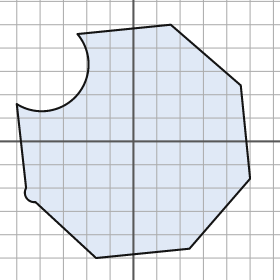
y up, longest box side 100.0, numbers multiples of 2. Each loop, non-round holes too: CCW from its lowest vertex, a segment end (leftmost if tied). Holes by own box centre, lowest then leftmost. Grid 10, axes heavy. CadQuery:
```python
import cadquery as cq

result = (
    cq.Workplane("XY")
    .moveTo(-16.0, -50.0)
    .lineTo(24.0, -46.0)
    .lineTo(50.0, -16.0)
    .lineTo(46.0, 24.0)
    .lineTo(16.0, 50.0)
    .lineTo(-24.0, 46.0)
    .threePointArc((-24.0, 20.0), (-50.0, 16.0))
    .lineTo(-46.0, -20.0)
    .threePointArc((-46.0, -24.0), (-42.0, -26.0))
    .close()
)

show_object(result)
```